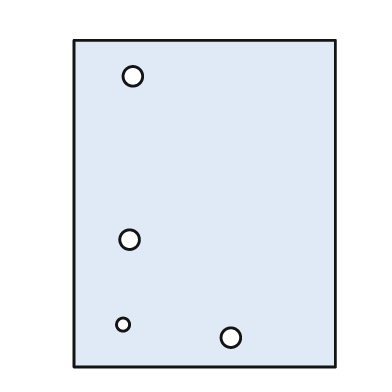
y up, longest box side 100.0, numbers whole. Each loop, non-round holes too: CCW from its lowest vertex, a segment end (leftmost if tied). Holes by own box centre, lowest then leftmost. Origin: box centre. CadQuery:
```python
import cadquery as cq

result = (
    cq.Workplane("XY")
    .moveTo(-40.0, -50.0)
    .lineTo(40.0, -50.0)
    .lineTo(40.0, 50.0)
    .lineTo(-40.0, 50.0)
    .close()
    .moveTo(8.0, -41.0)
    .circle(3.0)
    .moveTo(-25.0, -37.0)
    .circle(2.0)
    .moveTo(-23.0, -11.0)
    .circle(3.0)
    .moveTo(-22.0, 39.0)
    .circle(3.0)
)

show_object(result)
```